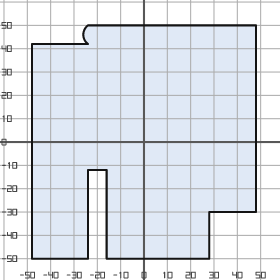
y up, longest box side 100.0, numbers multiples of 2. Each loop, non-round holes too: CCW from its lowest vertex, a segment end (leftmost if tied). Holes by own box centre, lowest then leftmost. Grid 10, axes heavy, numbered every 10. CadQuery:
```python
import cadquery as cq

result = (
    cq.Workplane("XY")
    .moveTo(-48.0, -50.0)
    .lineTo(-24.0, -50.0)
    .lineTo(-24.0, -12.0)
    .lineTo(-16.0, -12.0)
    .lineTo(-16.0, -50.0)
    .lineTo(28.0, -50.0)
    .lineTo(28.0, -30.0)
    .lineTo(48.0, -30.0)
    .lineTo(48.0, 50.0)
    .lineTo(-24.0, 50.0)
    .threePointArc((-26.0, 46.0), (-24.0, 42.0))
    .lineTo(-48.0, 42.0)
    .close()
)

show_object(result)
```